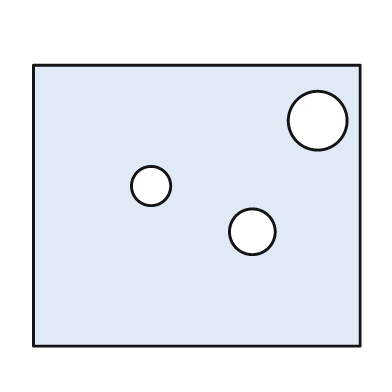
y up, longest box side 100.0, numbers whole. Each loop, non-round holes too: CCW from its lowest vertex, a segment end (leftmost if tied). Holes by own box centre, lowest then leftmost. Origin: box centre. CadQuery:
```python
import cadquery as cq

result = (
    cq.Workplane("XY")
    .moveTo(-50.0, -43.0)
    .lineTo(50.0, -43.0)
    .lineTo(50.0, 43.0)
    .lineTo(-50.0, 43.0)
    .close()
    .moveTo(17.0, -8.0)
    .circle(7.0)
    .moveTo(-14.0, 6.0)
    .circle(6.0)
    .moveTo(37.0, 26.0)
    .circle(9.0)
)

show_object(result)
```